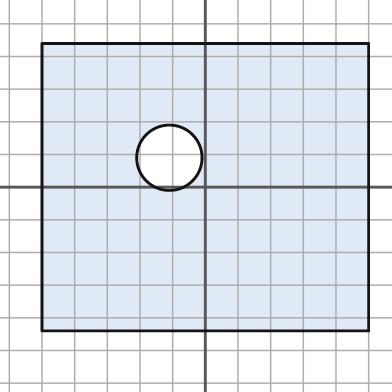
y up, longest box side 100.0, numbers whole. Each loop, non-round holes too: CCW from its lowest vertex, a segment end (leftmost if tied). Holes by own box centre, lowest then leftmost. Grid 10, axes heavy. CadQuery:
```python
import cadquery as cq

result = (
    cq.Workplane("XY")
    .moveTo(-50.0, -44.0)
    .lineTo(50.0, -44.0)
    .lineTo(50.0, 44.0)
    .lineTo(-50.0, 44.0)
    .close()
    .moveTo(-11.0, 9.0)
    .circle(10.0)
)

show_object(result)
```